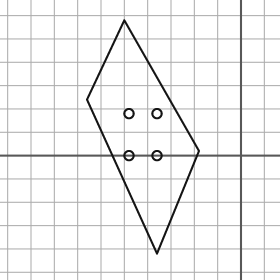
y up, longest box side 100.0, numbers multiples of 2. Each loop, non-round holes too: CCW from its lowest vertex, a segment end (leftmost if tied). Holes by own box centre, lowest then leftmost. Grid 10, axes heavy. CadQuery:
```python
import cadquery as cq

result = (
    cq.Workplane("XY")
    .moveTo(-36.0, -42.0)
    .lineTo(-18.0, 2.0)
    .lineTo(-50.0, 58.0)
    .lineTo(-66.0, 24.0)
    .close()
    .moveTo(-48.0, 0.0)
    .circle(2.0)
    .moveTo(-36.0, 0.0)
    .circle(2.0)
    .moveTo(-48.0, 18.0)
    .circle(2.0)
    .moveTo(-36.0, 18.0)
    .circle(2.0)
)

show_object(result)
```